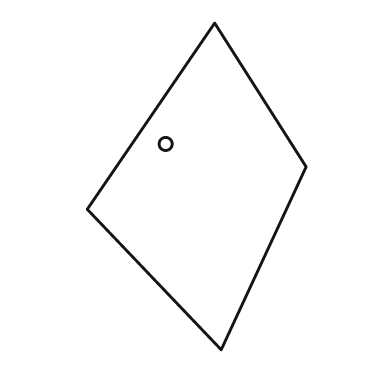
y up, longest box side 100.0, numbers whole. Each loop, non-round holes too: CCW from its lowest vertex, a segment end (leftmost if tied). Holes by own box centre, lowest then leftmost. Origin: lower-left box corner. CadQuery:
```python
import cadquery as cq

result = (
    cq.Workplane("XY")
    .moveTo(41.0, 0.0)
    .lineTo(67.0, 56.0)
    .lineTo(39.0, 100.0)
    .lineTo(0.0, 43.0)
    .close()
    .moveTo(24.0, 63.0)
    .circle(2.0)
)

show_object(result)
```